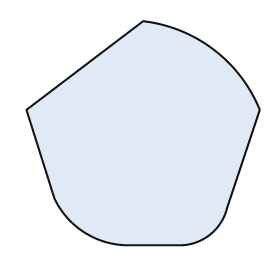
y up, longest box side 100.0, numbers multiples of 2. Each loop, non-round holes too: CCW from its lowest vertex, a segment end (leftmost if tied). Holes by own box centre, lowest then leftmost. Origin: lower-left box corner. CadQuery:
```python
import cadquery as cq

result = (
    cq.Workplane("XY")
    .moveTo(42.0, 0.0)
    .lineTo(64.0, 0.0)
    .threePointArc((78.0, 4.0), (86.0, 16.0))
    .lineTo(100.0, 58.0)
    .threePointArc((80.0, 84.0), (50.0, 96.0))
    .lineTo(0.0, 58.0)
    .lineTo(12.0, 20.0)
    .threePointArc((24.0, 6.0), (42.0, 0.0))
    .close()
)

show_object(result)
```